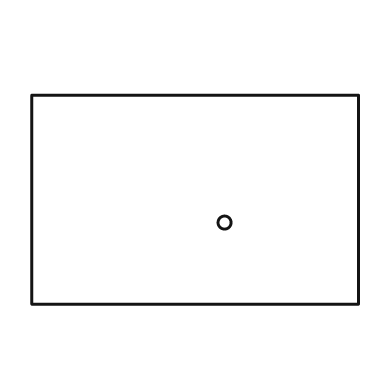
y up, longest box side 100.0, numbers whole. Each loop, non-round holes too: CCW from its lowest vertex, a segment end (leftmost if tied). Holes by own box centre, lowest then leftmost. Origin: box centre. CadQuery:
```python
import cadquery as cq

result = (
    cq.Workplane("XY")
    .moveTo(-50.0, -32.0)
    .lineTo(50.0, -32.0)
    .lineTo(50.0, 32.0)
    .lineTo(-50.0, 32.0)
    .close()
    .moveTo(9.0, -7.0)
    .circle(2.0)
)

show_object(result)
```